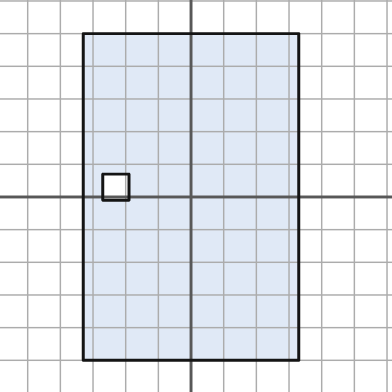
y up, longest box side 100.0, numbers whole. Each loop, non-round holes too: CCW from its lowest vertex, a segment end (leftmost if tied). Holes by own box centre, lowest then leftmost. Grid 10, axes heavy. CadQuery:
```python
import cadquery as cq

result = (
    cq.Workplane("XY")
    .moveTo(-33.0, -50.0)
    .lineTo(33.0, -50.0)
    .lineTo(33.0, 50.0)
    .lineTo(-33.0, 50.0)
    .close()
    .moveTo(-27.0, -1.0)
    .lineTo(-19.0, -1.0)
    .lineTo(-19.0, 7.0)
    .lineTo(-27.0, 7.0)
    .close()
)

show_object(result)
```